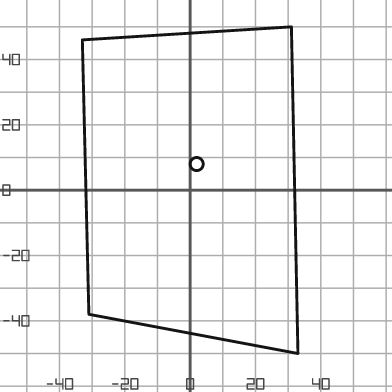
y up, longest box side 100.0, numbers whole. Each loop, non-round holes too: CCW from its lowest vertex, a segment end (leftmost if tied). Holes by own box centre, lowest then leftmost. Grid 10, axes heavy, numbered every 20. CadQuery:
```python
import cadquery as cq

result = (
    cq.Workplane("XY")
    .moveTo(33.0, -50.0)
    .lineTo(31.0, 50.0)
    .lineTo(-33.0, 46.0)
    .lineTo(-31.0, -38.0)
    .close()
    .moveTo(2.0, 8.0)
    .circle(2.0)
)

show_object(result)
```